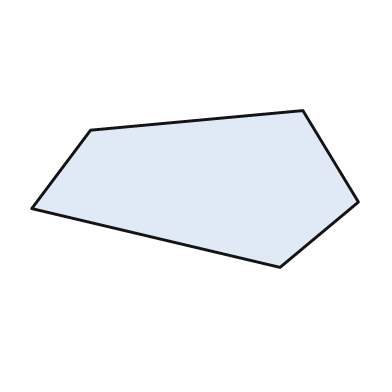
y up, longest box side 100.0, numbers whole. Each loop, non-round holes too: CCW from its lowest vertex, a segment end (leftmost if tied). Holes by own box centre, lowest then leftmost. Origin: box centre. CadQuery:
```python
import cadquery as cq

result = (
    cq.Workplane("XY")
    .moveTo(26.0, -24.0)
    .lineTo(50.0, -4.0)
    .lineTo(33.0, 24.0)
    .lineTo(-32.0, 18.0)
    .lineTo(-50.0, -6.0)
    .close()
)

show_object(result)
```